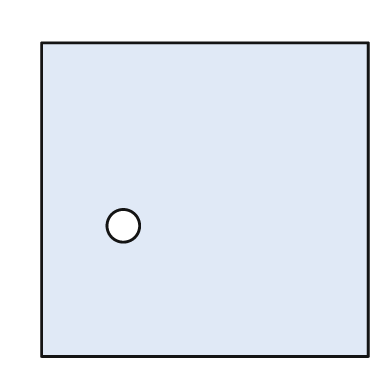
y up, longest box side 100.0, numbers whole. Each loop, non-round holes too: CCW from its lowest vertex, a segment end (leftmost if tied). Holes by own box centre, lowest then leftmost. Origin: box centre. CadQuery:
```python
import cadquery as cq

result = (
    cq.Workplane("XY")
    .moveTo(-50.0, -48.0)
    .lineTo(50.0, -48.0)
    .lineTo(50.0, 48.0)
    .lineTo(-50.0, 48.0)
    .close()
    .moveTo(-25.0, -8.0)
    .circle(5.0)
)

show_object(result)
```